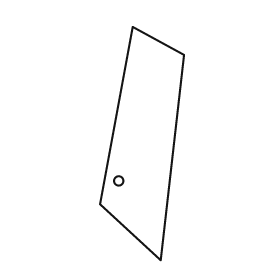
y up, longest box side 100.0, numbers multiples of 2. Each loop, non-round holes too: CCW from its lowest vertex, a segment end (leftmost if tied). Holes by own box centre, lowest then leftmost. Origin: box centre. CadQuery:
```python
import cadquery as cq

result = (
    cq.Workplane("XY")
    .moveTo(8.0, -50.0)
    .lineTo(18.0, 38.0)
    .lineTo(-4.0, 50.0)
    .lineTo(-18.0, -26.0)
    .close()
    .moveTo(-10.0, -16.0)
    .circle(2.0)
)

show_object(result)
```